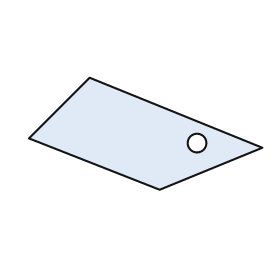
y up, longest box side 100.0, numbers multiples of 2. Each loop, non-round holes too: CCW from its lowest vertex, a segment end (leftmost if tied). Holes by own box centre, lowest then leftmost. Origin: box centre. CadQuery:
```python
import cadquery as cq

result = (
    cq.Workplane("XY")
    .moveTo(6.0, -24.0)
    .lineTo(50.0, -6.0)
    .lineTo(-24.0, 24.0)
    .lineTo(-50.0, -2.0)
    .close()
    .moveTo(22.0, -4.0)
    .circle(4.0)
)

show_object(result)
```